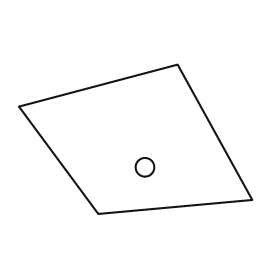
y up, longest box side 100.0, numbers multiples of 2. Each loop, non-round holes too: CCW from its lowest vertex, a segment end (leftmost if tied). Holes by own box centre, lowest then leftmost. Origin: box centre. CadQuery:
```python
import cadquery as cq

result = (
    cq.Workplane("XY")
    .moveTo(-16.0, -32.0)
    .lineTo(50.0, -26.0)
    .lineTo(18.0, 32.0)
    .lineTo(-50.0, 14.0)
    .close()
    .moveTo(4.0, -12.0)
    .circle(4.0)
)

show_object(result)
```